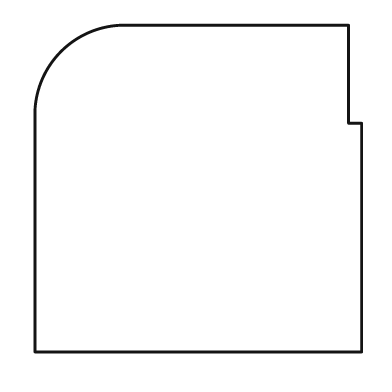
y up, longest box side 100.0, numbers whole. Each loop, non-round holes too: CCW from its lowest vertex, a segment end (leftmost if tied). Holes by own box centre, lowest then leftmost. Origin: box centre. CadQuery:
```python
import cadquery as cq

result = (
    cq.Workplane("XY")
    .moveTo(-50.0, -50.0)
    .lineTo(50.0, -50.0)
    .lineTo(50.0, 20.0)
    .lineTo(46.0, 20.0)
    .lineTo(46.0, 50.0)
    .lineTo(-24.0, 50.0)
    .threePointArc((-42.0, 42.0), (-50.0, 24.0))
    .close()
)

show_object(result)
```